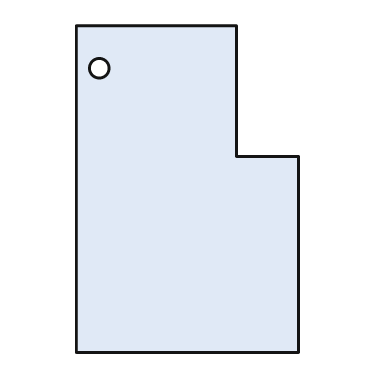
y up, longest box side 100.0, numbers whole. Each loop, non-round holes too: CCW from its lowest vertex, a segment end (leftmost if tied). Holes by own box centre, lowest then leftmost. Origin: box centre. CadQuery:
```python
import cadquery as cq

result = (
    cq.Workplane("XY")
    .moveTo(-34.0, -50.0)
    .lineTo(34.0, -50.0)
    .lineTo(34.0, 10.0)
    .lineTo(15.0, 10.0)
    .lineTo(15.0, 50.0)
    .lineTo(-34.0, 50.0)
    .close()
    .moveTo(-27.0, 37.0)
    .circle(3.0)
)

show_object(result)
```